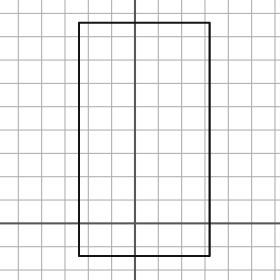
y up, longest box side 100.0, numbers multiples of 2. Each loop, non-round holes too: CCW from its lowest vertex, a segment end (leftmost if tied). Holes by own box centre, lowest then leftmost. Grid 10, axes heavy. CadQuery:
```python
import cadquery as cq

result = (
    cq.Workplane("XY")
    .moveTo(-24.0, -14.0)
    .lineTo(32.0, -14.0)
    .lineTo(32.0, 86.0)
    .lineTo(-24.0, 86.0)
    .close()
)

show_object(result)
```